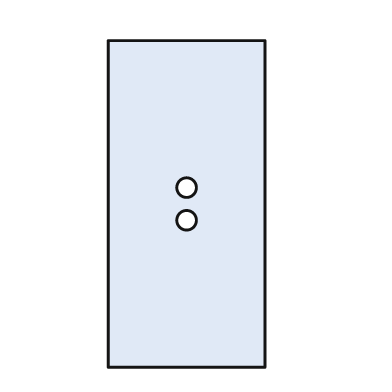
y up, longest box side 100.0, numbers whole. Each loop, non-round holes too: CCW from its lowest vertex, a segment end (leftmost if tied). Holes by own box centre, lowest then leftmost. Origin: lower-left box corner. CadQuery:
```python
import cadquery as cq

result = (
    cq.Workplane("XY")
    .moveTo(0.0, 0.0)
    .lineTo(48.0, 0.0)
    .lineTo(48.0, 100.0)
    .lineTo(0.0, 100.0)
    .close()
    .moveTo(24.0, 45.0)
    .circle(3.0)
    .moveTo(24.0, 55.0)
    .circle(3.0)
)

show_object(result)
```